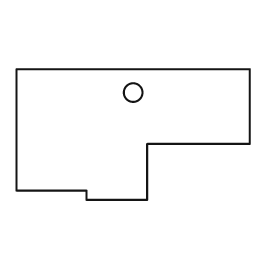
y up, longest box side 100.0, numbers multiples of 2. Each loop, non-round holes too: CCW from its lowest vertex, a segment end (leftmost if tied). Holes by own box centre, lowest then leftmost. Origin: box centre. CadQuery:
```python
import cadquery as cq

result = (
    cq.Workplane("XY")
    .moveTo(-20.0, -28.0)
    .lineTo(6.0, -28.0)
    .lineTo(6.0, -4.0)
    .lineTo(50.0, -4.0)
    .lineTo(50.0, 28.0)
    .lineTo(-50.0, 28.0)
    .lineTo(-50.0, -24.0)
    .lineTo(-20.0, -24.0)
    .close()
    .moveTo(0.0, 18.0)
    .circle(4.0)
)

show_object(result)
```